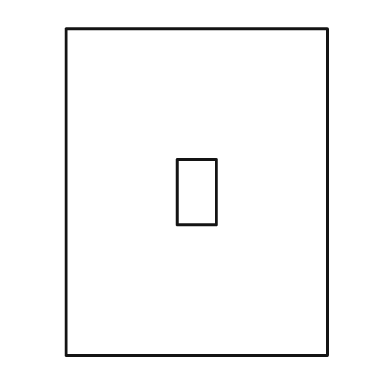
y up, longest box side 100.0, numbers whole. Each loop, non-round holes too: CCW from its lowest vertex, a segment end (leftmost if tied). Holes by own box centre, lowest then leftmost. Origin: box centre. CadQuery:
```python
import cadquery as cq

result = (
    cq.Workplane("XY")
    .moveTo(-40.0, -50.0)
    .lineTo(40.0, -50.0)
    .lineTo(40.0, 50.0)
    .lineTo(-40.0, 50.0)
    .close()
    .moveTo(-6.0, -10.0)
    .lineTo(6.0, -10.0)
    .lineTo(6.0, 10.0)
    .lineTo(-6.0, 10.0)
    .close()
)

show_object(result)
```